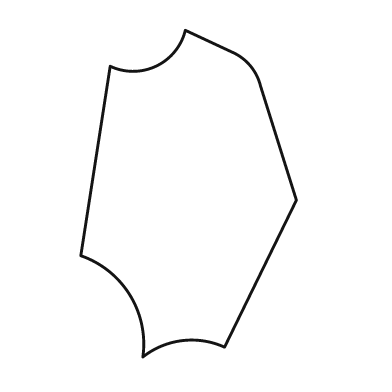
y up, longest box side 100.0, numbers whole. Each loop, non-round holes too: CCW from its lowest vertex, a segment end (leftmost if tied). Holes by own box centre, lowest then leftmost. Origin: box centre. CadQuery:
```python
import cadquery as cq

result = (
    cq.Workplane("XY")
    .moveTo(-14.0, -50.0)
    .threePointArc((-2.0, -45.0), (11.0, -47.0))
    .lineTo(33.0, -2.0)
    .lineTo(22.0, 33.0)
    .threePointArc((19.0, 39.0), (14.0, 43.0))
    .lineTo(-1.0, 50.0)
    .threePointArc((-10.0, 39.0), (-24.0, 39.0))
    .lineTo(-33.0, -19.0)
    .threePointArc((-18.0, -31.0), (-14.0, -50.0))
    .close()
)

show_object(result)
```